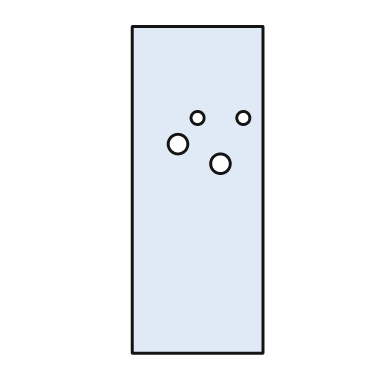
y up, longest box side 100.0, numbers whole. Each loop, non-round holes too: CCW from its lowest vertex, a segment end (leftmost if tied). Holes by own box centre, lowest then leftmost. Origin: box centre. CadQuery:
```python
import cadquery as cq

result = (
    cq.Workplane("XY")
    .moveTo(-20.0, -50.0)
    .lineTo(20.0, -50.0)
    .lineTo(20.0, 50.0)
    .lineTo(-20.0, 50.0)
    .close()
    .moveTo(7.0, 8.0)
    .circle(3.0)
    .moveTo(-6.0, 14.0)
    .circle(3.0)
    .moveTo(0.0, 22.0)
    .circle(2.0)
    .moveTo(14.0, 22.0)
    .circle(2.0)
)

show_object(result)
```